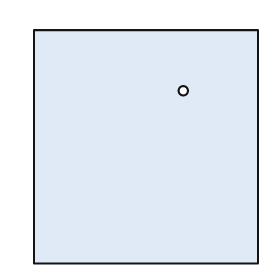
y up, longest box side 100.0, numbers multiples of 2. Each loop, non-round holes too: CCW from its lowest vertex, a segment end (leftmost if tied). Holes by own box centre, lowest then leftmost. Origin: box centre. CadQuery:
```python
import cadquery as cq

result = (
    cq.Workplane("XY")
    .moveTo(-48.0, -50.0)
    .lineTo(48.0, -50.0)
    .lineTo(48.0, 50.0)
    .lineTo(-48.0, 50.0)
    .close()
    .moveTo(16.0, 24.0)
    .circle(2.0)
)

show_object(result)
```